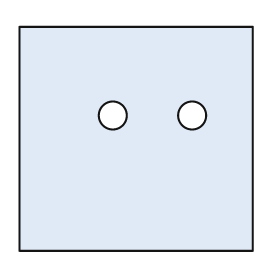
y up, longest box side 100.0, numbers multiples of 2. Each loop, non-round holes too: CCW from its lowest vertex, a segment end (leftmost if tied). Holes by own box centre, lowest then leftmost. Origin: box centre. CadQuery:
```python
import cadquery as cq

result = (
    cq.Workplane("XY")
    .moveTo(-50.0, -48.0)
    .lineTo(50.0, -48.0)
    .lineTo(50.0, 48.0)
    .lineTo(-50.0, 48.0)
    .close()
    .moveTo(-10.0, 10.0)
    .circle(6.0)
    .moveTo(24.0, 10.0)
    .circle(6.0)
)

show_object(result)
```